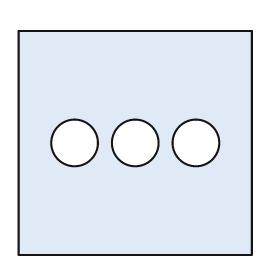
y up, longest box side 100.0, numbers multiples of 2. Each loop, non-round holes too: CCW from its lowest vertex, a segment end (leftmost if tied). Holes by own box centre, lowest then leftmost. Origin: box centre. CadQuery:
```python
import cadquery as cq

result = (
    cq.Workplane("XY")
    .moveTo(-50.0, -48.0)
    .lineTo(50.0, -48.0)
    .lineTo(50.0, 48.0)
    .lineTo(-50.0, 48.0)
    .close()
    .moveTo(-26.0, 0.0)
    .circle(10.0)
    .moveTo(0.0, 0.0)
    .circle(10.0)
    .moveTo(26.0, 0.0)
    .circle(10.0)
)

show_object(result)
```